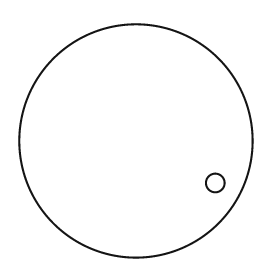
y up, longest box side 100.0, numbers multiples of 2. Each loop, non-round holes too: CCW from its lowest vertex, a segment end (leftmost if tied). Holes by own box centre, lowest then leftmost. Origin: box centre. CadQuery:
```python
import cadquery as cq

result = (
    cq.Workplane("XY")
    .moveTo(0.0, 0.0)
    .circle(50.0)
    .moveTo(34.0, -18.0)
    .circle(4.0)
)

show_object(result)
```